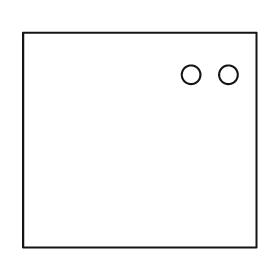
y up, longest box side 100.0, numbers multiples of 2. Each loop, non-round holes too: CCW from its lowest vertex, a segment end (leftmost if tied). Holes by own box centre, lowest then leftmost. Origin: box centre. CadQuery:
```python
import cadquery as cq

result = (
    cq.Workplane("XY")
    .moveTo(-50.0, -46.0)
    .lineTo(50.0, -46.0)
    .lineTo(50.0, 46.0)
    .lineTo(-50.0, 46.0)
    .close()
    .moveTo(22.0, 28.0)
    .circle(4.0)
    .moveTo(38.0, 28.0)
    .circle(4.0)
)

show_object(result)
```